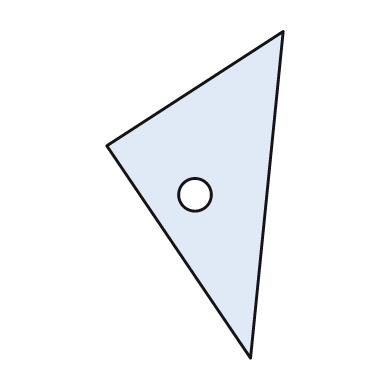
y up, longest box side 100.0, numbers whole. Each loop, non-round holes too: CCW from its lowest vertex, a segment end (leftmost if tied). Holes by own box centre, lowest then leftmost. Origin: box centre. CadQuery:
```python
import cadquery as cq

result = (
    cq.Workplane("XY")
    .moveTo(17.0, -50.0)
    .lineTo(27.0, 50.0)
    .lineTo(-27.0, 15.0)
    .close()
    .moveTo(0.0, 0.0)
    .circle(5.0)
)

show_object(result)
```